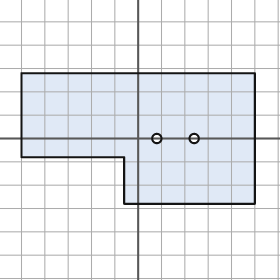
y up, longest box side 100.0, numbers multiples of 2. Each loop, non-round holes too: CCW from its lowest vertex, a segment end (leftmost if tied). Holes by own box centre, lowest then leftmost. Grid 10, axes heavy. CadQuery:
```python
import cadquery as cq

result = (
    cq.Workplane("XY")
    .moveTo(-6.0, -28.0)
    .lineTo(50.0, -28.0)
    .lineTo(50.0, 28.0)
    .lineTo(-50.0, 28.0)
    .lineTo(-50.0, -8.0)
    .lineTo(-6.0, -8.0)
    .close()
    .moveTo(8.0, 0.0)
    .circle(2.0)
    .moveTo(24.0, 0.0)
    .circle(2.0)
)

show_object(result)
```